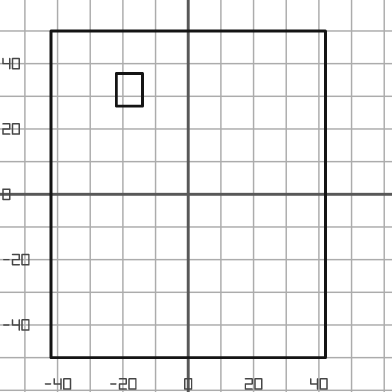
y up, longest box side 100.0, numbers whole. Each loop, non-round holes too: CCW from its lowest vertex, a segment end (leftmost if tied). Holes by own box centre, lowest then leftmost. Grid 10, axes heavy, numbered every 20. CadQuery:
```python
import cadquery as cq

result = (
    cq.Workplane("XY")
    .moveTo(-42.0, -50.0)
    .lineTo(42.0, -50.0)
    .lineTo(42.0, 50.0)
    .lineTo(-42.0, 50.0)
    .close()
    .moveTo(-22.0, 27.0)
    .lineTo(-14.0, 27.0)
    .lineTo(-14.0, 37.0)
    .lineTo(-22.0, 37.0)
    .close()
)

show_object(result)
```